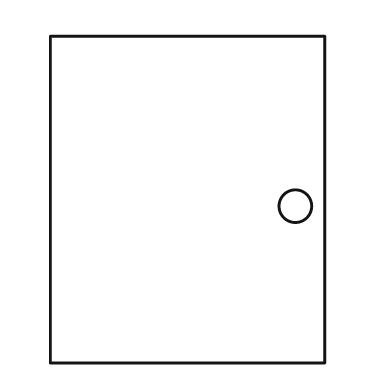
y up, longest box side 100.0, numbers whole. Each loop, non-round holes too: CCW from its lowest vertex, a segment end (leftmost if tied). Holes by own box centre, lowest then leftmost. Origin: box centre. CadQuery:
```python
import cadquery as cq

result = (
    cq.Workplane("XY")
    .moveTo(-42.0, -50.0)
    .lineTo(42.0, -50.0)
    .lineTo(42.0, 50.0)
    .lineTo(-42.0, 50.0)
    .close()
    .moveTo(33.0, -2.0)
    .circle(5.0)
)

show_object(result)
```